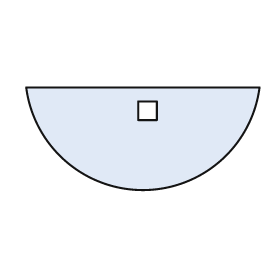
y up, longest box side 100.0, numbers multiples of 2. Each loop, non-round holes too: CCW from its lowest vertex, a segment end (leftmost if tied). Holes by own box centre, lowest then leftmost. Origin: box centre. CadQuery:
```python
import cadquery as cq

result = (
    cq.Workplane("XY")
    .moveTo(-50.0, 22.0)
    .threePointArc((0.0, -22.0), (50.0, 22.0))
    .close()
    .moveTo(-2.0, 8.0)
    .lineTo(6.0, 8.0)
    .lineTo(6.0, 16.0)
    .lineTo(-2.0, 16.0)
    .close()
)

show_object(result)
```